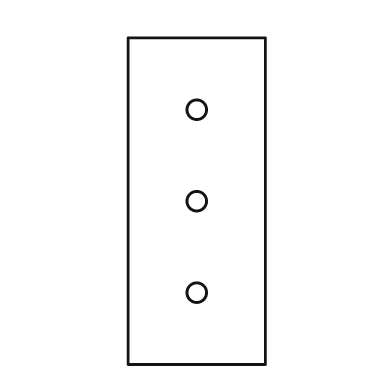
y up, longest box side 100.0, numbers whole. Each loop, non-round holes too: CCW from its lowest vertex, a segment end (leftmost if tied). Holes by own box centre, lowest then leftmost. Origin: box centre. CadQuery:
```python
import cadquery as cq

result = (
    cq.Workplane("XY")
    .moveTo(-21.0, -50.0)
    .lineTo(21.0, -50.0)
    .lineTo(21.0, 50.0)
    .lineTo(-21.0, 50.0)
    .close()
    .moveTo(0.0, -28.0)
    .circle(3.0)
    .moveTo(0.0, 0.0)
    .circle(3.0)
    .moveTo(0.0, 28.0)
    .circle(3.0)
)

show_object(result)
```